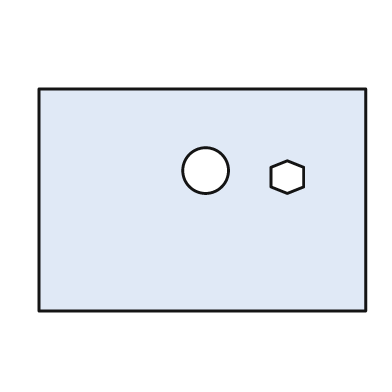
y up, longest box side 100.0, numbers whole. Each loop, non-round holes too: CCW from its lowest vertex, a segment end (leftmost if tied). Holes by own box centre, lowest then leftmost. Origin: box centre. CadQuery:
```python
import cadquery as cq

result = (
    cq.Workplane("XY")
    .moveTo(-50.0, -34.0)
    .lineTo(50.0, -34.0)
    .lineTo(50.0, 34.0)
    .lineTo(-50.0, 34.0)
    .close()
    .moveTo(26.0, 2.0)
    .lineTo(31.0, 4.0)
    .lineTo(31.0, 10.0)
    .lineTo(26.0, 12.0)
    .lineTo(21.0, 10.0)
    .lineTo(21.0, 4.0)
    .close()
    .moveTo(1.0, 9.0)
    .circle(7.0)
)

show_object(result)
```